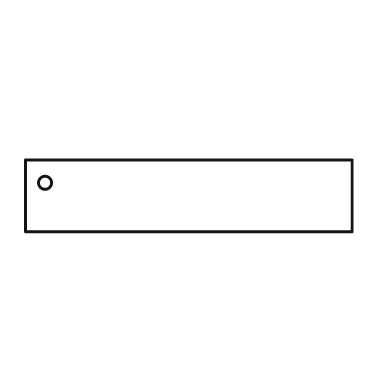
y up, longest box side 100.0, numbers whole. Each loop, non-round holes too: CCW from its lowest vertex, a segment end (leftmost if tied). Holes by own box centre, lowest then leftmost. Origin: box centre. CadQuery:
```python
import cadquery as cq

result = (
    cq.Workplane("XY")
    .moveTo(-50.0, -11.0)
    .lineTo(50.0, -11.0)
    .lineTo(50.0, 11.0)
    .lineTo(-50.0, 11.0)
    .close()
    .moveTo(-44.0, 4.0)
    .circle(2.0)
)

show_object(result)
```